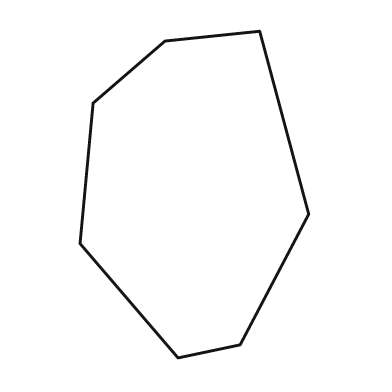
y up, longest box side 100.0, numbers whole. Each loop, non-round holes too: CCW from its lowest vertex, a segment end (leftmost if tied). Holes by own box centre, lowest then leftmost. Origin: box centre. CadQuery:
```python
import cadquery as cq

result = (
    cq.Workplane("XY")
    .moveTo(-5.0, -50.0)
    .lineTo(14.0, -46.0)
    .lineTo(35.0, -6.0)
    .lineTo(20.0, 50.0)
    .lineTo(-9.0, 47.0)
    .lineTo(-31.0, 28.0)
    .lineTo(-35.0, -15.0)
    .close()
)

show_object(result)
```